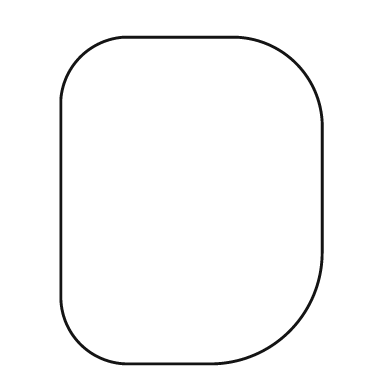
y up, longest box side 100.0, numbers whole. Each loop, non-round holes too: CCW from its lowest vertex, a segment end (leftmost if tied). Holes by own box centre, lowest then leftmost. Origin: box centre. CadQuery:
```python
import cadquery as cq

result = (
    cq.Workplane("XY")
    .moveTo(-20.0, -50.0)
    .lineTo(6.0, -50.0)
    .threePointArc((30.0, -40.0), (40.0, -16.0))
    .lineTo(40.0, 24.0)
    .threePointArc((32.0, 42.0), (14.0, 50.0))
    .lineTo(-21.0, 50.0)
    .threePointArc((-34.0, 44.0), (-40.0, 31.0))
    .lineTo(-40.0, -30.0)
    .threePointArc((-34.0, -44.0), (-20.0, -50.0))
    .close()
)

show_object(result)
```